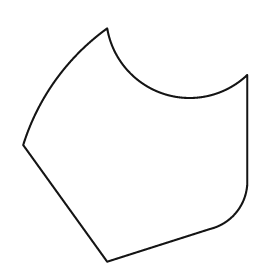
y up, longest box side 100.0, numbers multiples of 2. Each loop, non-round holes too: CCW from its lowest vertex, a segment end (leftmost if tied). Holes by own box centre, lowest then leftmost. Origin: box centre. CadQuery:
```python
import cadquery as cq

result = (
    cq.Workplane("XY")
    .moveTo(-12.0, -50.0)
    .lineTo(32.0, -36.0)
    .threePointArc((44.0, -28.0), (48.0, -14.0))
    .lineTo(48.0, 30.0)
    .threePointArc((12.0, 22.0), (-12.0, 50.0))
    .threePointArc((-34.0, 28.0), (-48.0, 0.0))
    .close()
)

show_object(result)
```